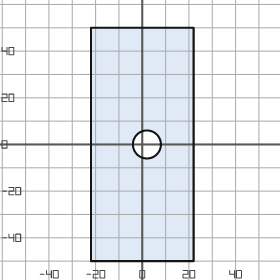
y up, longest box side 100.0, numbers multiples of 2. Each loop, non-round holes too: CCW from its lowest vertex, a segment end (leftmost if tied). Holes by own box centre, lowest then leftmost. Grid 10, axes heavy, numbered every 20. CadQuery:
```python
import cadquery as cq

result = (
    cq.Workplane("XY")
    .moveTo(-22.0, -50.0)
    .lineTo(22.0, -50.0)
    .lineTo(22.0, 50.0)
    .lineTo(-22.0, 50.0)
    .close()
    .moveTo(2.0, 0.0)
    .circle(6.0)
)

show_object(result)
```